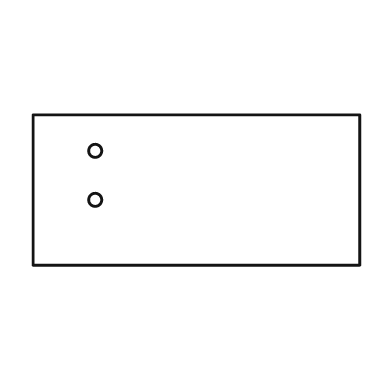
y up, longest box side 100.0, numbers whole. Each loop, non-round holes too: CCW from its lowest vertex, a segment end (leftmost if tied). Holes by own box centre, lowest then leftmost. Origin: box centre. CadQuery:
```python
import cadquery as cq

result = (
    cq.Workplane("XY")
    .moveTo(-50.0, -23.0)
    .lineTo(50.0, -23.0)
    .lineTo(50.0, 23.0)
    .lineTo(-50.0, 23.0)
    .close()
    .moveTo(-31.0, -3.0)
    .circle(2.0)
    .moveTo(-31.0, 12.0)
    .circle(2.0)
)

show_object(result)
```